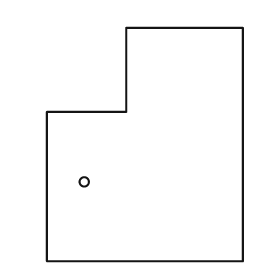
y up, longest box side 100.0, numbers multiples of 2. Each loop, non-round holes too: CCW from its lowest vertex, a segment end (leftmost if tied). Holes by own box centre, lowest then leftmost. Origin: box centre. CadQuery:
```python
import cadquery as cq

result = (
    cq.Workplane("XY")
    .moveTo(-42.0, -50.0)
    .lineTo(42.0, -50.0)
    .lineTo(42.0, 50.0)
    .lineTo(-8.0, 50.0)
    .lineTo(-8.0, 14.0)
    .lineTo(-42.0, 14.0)
    .close()
    .moveTo(-26.0, -16.0)
    .circle(2.0)
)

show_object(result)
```